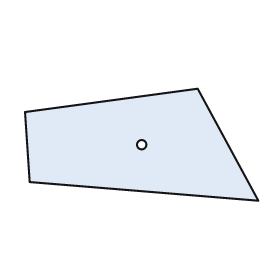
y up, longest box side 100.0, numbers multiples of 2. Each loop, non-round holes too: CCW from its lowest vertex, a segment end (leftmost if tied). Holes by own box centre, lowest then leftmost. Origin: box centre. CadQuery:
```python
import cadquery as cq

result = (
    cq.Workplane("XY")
    .moveTo(50.0, -24.0)
    .lineTo(24.0, 24.0)
    .lineTo(-50.0, 14.0)
    .lineTo(-48.0, -16.0)
    .close()
    .moveTo(0.0, 0.0)
    .circle(2.0)
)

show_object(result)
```